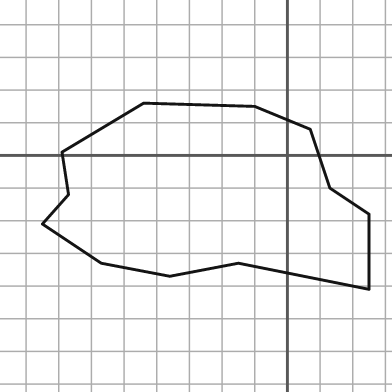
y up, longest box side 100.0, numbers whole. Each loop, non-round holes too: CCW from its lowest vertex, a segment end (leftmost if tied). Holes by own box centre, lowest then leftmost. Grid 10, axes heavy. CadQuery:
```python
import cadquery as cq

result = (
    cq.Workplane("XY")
    .moveTo(25.0, -41.0)
    .lineTo(25.0, -18.0)
    .lineTo(13.0, -10.0)
    .lineTo(7.0, 8.0)
    .lineTo(-10.0, 15.0)
    .lineTo(-44.0, 16.0)
    .lineTo(-69.0, 1.0)
    .lineTo(-67.0, -12.0)
    .lineTo(-75.0, -21.0)
    .lineTo(-57.0, -33.0)
    .lineTo(-36.0, -37.0)
    .lineTo(-15.0, -33.0)
    .close()
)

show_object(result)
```